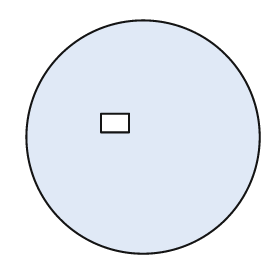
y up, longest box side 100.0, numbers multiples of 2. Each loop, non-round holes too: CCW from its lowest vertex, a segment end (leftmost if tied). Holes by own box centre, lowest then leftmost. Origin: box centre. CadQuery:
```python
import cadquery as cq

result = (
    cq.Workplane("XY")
    .moveTo(0.0, 0.0)
    .circle(50.0)
    .moveTo(-18.0, 2.0)
    .lineTo(-6.0, 2.0)
    .lineTo(-6.0, 10.0)
    .lineTo(-18.0, 10.0)
    .close()
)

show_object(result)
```